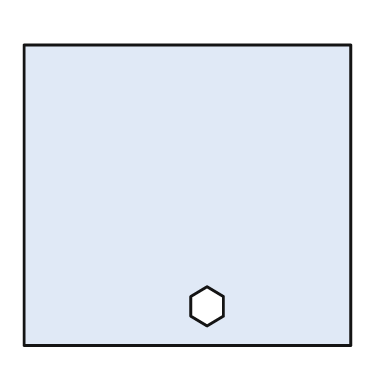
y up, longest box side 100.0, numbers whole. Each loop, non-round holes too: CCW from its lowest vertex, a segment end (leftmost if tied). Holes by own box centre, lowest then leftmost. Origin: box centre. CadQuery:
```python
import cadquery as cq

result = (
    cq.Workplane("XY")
    .moveTo(-50.0, -46.0)
    .lineTo(50.0, -46.0)
    .lineTo(50.0, 46.0)
    .lineTo(-50.0, 46.0)
    .close()
    .moveTo(6.0, -40.0)
    .lineTo(11.0, -37.0)
    .lineTo(11.0, -31.0)
    .lineTo(6.0, -28.0)
    .lineTo(1.0, -31.0)
    .lineTo(1.0, -37.0)
    .close()
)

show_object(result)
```